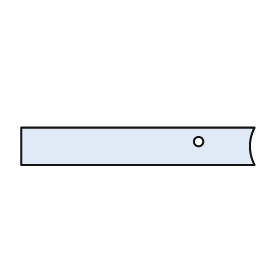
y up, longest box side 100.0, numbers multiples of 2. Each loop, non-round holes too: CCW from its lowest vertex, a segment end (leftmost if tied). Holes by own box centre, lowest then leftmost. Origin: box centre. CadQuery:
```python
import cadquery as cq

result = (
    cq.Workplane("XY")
    .moveTo(-50.0, -8.0)
    .lineTo(50.0, -8.0)
    .threePointArc((48.0, 0.0), (50.0, 8.0))
    .lineTo(-50.0, 8.0)
    .close()
    .moveTo(26.0, 2.0)
    .circle(2.0)
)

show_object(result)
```